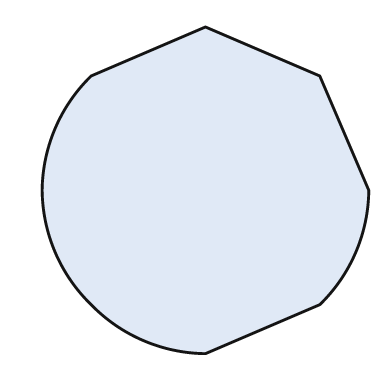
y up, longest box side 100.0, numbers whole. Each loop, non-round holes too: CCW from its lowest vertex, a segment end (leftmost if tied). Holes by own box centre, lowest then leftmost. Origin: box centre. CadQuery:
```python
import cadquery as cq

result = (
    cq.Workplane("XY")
    .moveTo(0.0, -50.0)
    .lineTo(35.0, -35.0)
    .threePointArc((46.0, -19.0), (50.0, 0.0))
    .lineTo(35.0, 35.0)
    .lineTo(0.0, 50.0)
    .lineTo(-35.0, 35.0)
    .threePointArc((-46.0, 19.0), (-50.0, 0.0))
    .threePointArc((-46.0, -19.0), (-35.0, -35.0))
    .threePointArc((-19.0, -46.0), (0.0, -50.0))
    .close()
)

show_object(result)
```